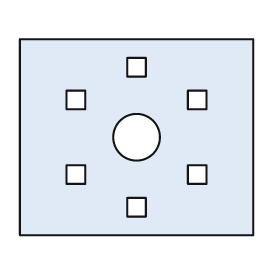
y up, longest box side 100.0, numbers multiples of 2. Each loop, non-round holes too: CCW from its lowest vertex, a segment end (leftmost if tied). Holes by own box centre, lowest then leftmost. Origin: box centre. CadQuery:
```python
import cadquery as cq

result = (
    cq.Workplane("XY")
    .moveTo(-50.0, -42.0)
    .lineTo(50.0, -42.0)
    .lineTo(50.0, 42.0)
    .lineTo(-50.0, 42.0)
    .close()
    .moveTo(-4.0, -34.0)
    .lineTo(4.0, -34.0)
    .lineTo(4.0, -26.0)
    .lineTo(-4.0, -26.0)
    .close()
    .moveTo(-30.0, -20.0)
    .lineTo(-22.0, -20.0)
    .lineTo(-22.0, -12.0)
    .lineTo(-30.0, -12.0)
    .close()
    .moveTo(22.0, -20.0)
    .lineTo(30.0, -20.0)
    .lineTo(30.0, -12.0)
    .lineTo(22.0, -12.0)
    .close()
    .moveTo(0.0, 0.0)
    .circle(10.0)
    .moveTo(-30.0, 12.0)
    .lineTo(-22.0, 12.0)
    .lineTo(-22.0, 20.0)
    .lineTo(-30.0, 20.0)
    .close()
    .moveTo(22.0, 12.0)
    .lineTo(30.0, 12.0)
    .lineTo(30.0, 20.0)
    .lineTo(22.0, 20.0)
    .close()
    .moveTo(-4.0, 26.0)
    .lineTo(4.0, 26.0)
    .lineTo(4.0, 34.0)
    .lineTo(-4.0, 34.0)
    .close()
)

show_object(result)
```